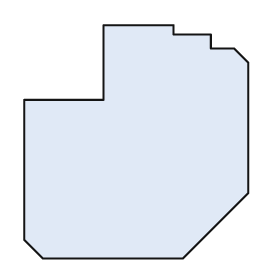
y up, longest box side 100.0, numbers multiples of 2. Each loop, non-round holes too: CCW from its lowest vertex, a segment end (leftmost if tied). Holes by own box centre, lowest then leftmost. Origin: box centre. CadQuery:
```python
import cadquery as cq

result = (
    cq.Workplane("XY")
    .moveTo(-40.0, -50.0)
    .lineTo(20.0, -50.0)
    .lineTo(48.0, -22.0)
    .lineTo(48.0, 34.0)
    .lineTo(42.0, 40.0)
    .lineTo(32.0, 40.0)
    .lineTo(32.0, 46.0)
    .lineTo(16.0, 46.0)
    .lineTo(16.0, 50.0)
    .lineTo(-14.0, 50.0)
    .lineTo(-14.0, 18.0)
    .lineTo(-48.0, 18.0)
    .lineTo(-48.0, -42.0)
    .close()
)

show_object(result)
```